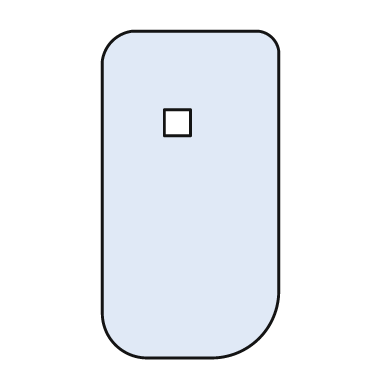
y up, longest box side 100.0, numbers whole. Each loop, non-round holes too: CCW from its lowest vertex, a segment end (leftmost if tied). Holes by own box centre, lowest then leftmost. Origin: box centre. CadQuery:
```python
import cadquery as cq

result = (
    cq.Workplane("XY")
    .moveTo(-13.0, -50.0)
    .lineTo(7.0, -50.0)
    .threePointArc((21.0, -44.0), (27.0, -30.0))
    .lineTo(27.0, 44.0)
    .threePointArc((25.0, 48.0), (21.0, 50.0))
    .lineTo(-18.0, 50.0)
    .threePointArc((-24.0, 47.0), (-27.0, 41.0))
    .lineTo(-27.0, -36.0)
    .threePointArc((-23.0, -46.0), (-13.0, -50.0))
    .close()
    .moveTo(-8.0, 18.0)
    .lineTo(0.0, 18.0)
    .lineTo(0.0, 26.0)
    .lineTo(-8.0, 26.0)
    .close()
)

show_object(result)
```